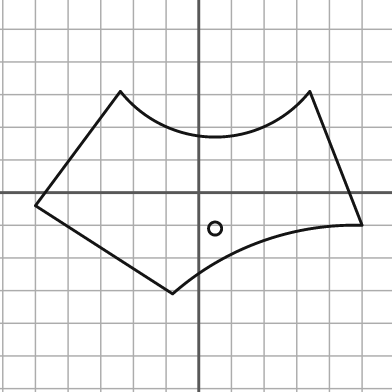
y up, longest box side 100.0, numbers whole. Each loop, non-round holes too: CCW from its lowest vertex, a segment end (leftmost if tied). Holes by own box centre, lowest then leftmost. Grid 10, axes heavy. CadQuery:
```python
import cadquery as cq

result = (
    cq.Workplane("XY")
    .moveTo(-8.0, -31.0)
    .threePointArc((19.0, -15.0), (50.0, -10.0))
    .lineTo(34.0, 31.0)
    .threePointArc((5.0, 17.0), (-24.0, 31.0))
    .lineTo(-50.0, -4.0)
    .close()
    .moveTo(5.0, -11.0)
    .circle(2.0)
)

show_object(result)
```